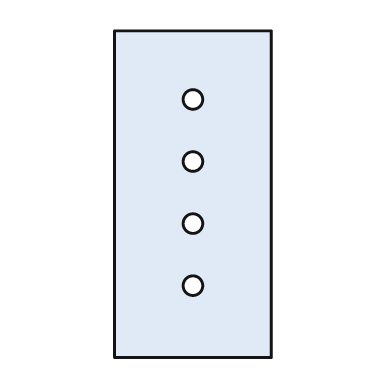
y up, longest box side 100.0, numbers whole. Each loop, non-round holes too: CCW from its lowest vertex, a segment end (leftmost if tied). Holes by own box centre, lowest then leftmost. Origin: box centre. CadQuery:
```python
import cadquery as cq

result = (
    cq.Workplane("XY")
    .moveTo(-24.0, -50.0)
    .lineTo(24.0, -50.0)
    .lineTo(24.0, 50.0)
    .lineTo(-24.0, 50.0)
    .close()
    .moveTo(0.0, -28.0)
    .circle(3.0)
    .moveTo(0.0, -9.0)
    .circle(3.0)
    .moveTo(0.0, 10.0)
    .circle(3.0)
    .moveTo(0.0, 29.0)
    .circle(3.0)
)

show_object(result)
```